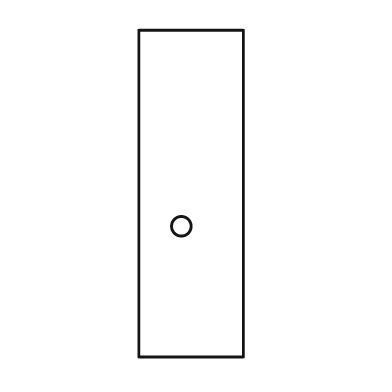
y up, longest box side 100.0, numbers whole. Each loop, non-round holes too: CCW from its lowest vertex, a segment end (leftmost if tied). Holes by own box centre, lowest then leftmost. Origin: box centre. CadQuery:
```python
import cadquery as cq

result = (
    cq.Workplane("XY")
    .moveTo(-16.0, -50.0)
    .lineTo(16.0, -50.0)
    .lineTo(16.0, 50.0)
    .lineTo(-16.0, 50.0)
    .close()
    .moveTo(-3.0, -10.0)
    .circle(3.0)
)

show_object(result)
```